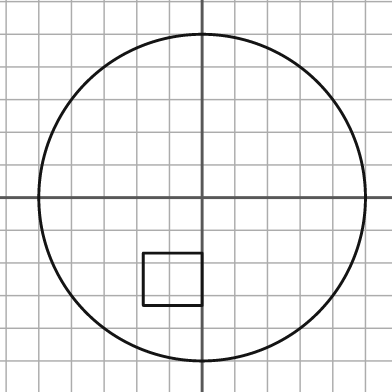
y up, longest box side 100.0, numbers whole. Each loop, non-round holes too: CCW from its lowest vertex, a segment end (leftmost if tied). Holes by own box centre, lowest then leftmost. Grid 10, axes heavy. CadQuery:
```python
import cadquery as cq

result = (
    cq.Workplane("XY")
    .moveTo(0.0, 0.0)
    .circle(50.0)
    .moveTo(-18.0, -33.0)
    .lineTo(0.0, -33.0)
    .lineTo(0.0, -17.0)
    .lineTo(-18.0, -17.0)
    .close()
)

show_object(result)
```